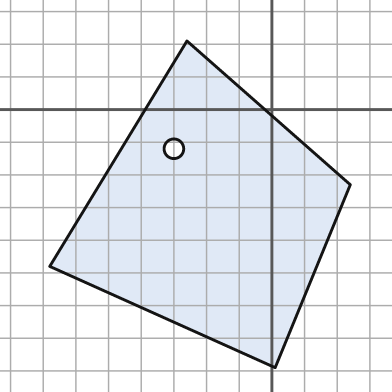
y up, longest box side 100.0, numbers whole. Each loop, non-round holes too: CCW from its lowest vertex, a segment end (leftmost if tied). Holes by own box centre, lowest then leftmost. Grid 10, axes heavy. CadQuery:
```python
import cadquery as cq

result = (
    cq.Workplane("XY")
    .moveTo(1.0, -79.0)
    .lineTo(24.0, -23.0)
    .lineTo(-26.0, 21.0)
    .lineTo(-68.0, -48.0)
    .close()
    .moveTo(-30.0, -12.0)
    .circle(3.0)
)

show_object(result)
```